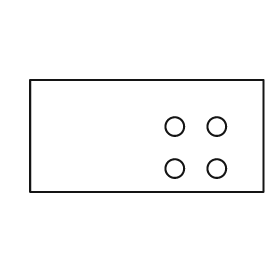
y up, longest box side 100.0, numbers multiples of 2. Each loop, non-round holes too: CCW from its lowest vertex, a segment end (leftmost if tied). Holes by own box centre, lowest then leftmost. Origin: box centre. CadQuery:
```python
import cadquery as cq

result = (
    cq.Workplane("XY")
    .moveTo(-50.0, -24.0)
    .lineTo(50.0, -24.0)
    .lineTo(50.0, 24.0)
    .lineTo(-50.0, 24.0)
    .close()
    .moveTo(12.0, -14.0)
    .circle(4.0)
    .moveTo(30.0, -14.0)
    .circle(4.0)
    .moveTo(12.0, 4.0)
    .circle(4.0)
    .moveTo(30.0, 4.0)
    .circle(4.0)
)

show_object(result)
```